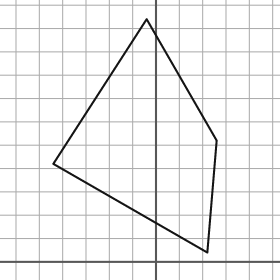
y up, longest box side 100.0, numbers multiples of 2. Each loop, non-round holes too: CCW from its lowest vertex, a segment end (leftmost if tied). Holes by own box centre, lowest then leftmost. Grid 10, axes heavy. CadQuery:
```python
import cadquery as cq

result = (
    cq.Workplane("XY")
    .moveTo(22.0, 4.0)
    .lineTo(26.0, 52.0)
    .lineTo(-4.0, 104.0)
    .lineTo(-44.0, 42.0)
    .close()
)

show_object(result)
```